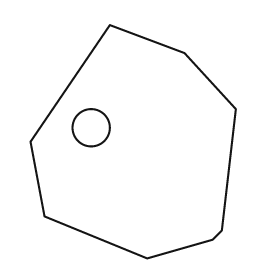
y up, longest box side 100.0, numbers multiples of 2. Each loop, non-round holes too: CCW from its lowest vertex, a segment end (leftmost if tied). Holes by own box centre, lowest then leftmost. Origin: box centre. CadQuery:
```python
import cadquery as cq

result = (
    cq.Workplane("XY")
    .moveTo(6.0, -50.0)
    .lineTo(34.0, -42.0)
    .lineTo(38.0, -38.0)
    .lineTo(44.0, 14.0)
    .lineTo(22.0, 38.0)
    .lineTo(-10.0, 50.0)
    .lineTo(-44.0, 0.0)
    .lineTo(-38.0, -32.0)
    .close()
    .moveTo(-18.0, 6.0)
    .circle(8.0)
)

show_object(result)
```